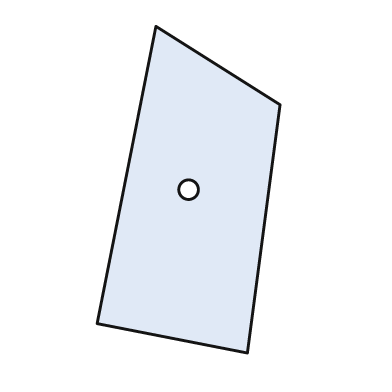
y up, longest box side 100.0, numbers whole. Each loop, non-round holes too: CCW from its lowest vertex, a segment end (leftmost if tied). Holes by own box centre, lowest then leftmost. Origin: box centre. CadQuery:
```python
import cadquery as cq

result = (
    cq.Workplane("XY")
    .moveTo(18.0, -50.0)
    .lineTo(28.0, 26.0)
    .lineTo(-10.0, 50.0)
    .lineTo(-28.0, -41.0)
    .close()
    .moveTo(0.0, 0.0)
    .circle(3.0)
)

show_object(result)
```